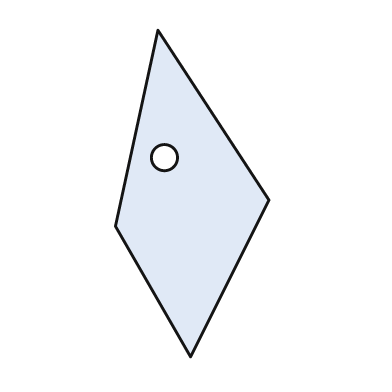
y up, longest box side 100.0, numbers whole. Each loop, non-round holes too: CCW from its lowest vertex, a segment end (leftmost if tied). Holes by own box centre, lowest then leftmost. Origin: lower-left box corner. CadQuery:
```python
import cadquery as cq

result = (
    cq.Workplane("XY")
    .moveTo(23.0, 0.0)
    .lineTo(47.0, 48.0)
    .lineTo(13.0, 100.0)
    .lineTo(0.0, 40.0)
    .close()
    .moveTo(15.0, 61.0)
    .circle(4.0)
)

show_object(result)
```